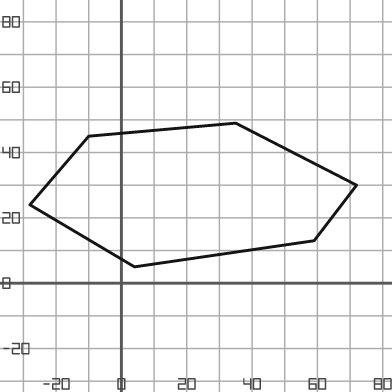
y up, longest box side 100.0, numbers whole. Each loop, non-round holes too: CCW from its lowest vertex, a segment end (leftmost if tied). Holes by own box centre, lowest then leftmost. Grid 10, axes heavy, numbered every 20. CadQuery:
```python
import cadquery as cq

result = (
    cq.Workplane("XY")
    .moveTo(4.0, 5.0)
    .lineTo(59.0, 13.0)
    .lineTo(72.0, 30.0)
    .lineTo(35.0, 49.0)
    .lineTo(-10.0, 45.0)
    .lineTo(-28.0, 24.0)
    .close()
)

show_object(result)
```